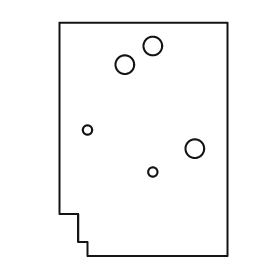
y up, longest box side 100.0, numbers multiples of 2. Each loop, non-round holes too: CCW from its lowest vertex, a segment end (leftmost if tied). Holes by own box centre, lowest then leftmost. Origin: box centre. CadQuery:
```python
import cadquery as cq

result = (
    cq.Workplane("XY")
    .moveTo(-24.0, -50.0)
    .lineTo(36.0, -50.0)
    .lineTo(36.0, 50.0)
    .lineTo(-36.0, 50.0)
    .lineTo(-36.0, -32.0)
    .lineTo(-28.0, -32.0)
    .lineTo(-28.0, -44.0)
    .lineTo(-24.0, -44.0)
    .close()
    .moveTo(4.0, -14.0)
    .circle(2.0)
    .moveTo(22.0, -4.0)
    .circle(4.0)
    .moveTo(-24.0, 4.0)
    .circle(2.0)
    .moveTo(-8.0, 32.0)
    .circle(4.0)
    .moveTo(4.0, 40.0)
    .circle(4.0)
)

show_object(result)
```